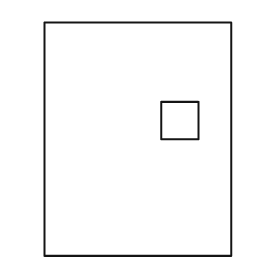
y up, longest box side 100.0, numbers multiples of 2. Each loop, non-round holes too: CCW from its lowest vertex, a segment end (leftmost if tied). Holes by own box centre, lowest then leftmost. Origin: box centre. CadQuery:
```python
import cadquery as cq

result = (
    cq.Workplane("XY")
    .moveTo(-40.0, -50.0)
    .lineTo(40.0, -50.0)
    .lineTo(40.0, 50.0)
    .lineTo(-40.0, 50.0)
    .close()
    .moveTo(10.0, 0.0)
    .lineTo(26.0, 0.0)
    .lineTo(26.0, 16.0)
    .lineTo(10.0, 16.0)
    .close()
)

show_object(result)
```